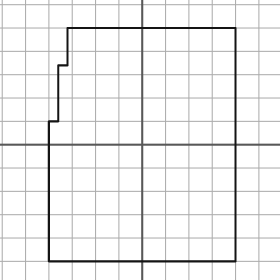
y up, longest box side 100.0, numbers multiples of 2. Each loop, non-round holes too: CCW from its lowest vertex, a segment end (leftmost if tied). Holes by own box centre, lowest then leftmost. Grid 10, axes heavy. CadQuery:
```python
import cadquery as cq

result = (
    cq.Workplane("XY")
    .moveTo(-40.0, -50.0)
    .lineTo(40.0, -50.0)
    .lineTo(40.0, 50.0)
    .lineTo(-32.0, 50.0)
    .lineTo(-32.0, 34.0)
    .lineTo(-36.0, 34.0)
    .lineTo(-36.0, 10.0)
    .lineTo(-40.0, 10.0)
    .close()
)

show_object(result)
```